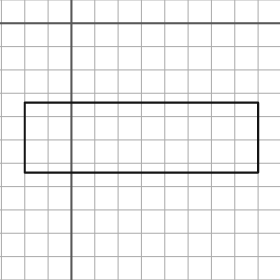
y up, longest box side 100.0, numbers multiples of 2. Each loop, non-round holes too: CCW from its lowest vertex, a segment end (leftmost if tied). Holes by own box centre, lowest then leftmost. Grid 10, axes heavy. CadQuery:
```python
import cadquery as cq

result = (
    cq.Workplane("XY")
    .moveTo(-20.0, -64.0)
    .lineTo(80.0, -64.0)
    .lineTo(80.0, -34.0)
    .lineTo(-20.0, -34.0)
    .close()
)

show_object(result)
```